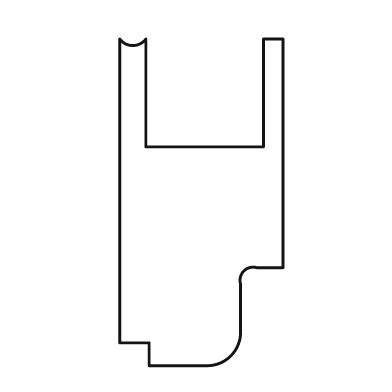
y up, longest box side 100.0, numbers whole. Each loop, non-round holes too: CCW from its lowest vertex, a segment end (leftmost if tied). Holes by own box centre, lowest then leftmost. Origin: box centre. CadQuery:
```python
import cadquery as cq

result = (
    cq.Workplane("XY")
    .moveTo(-16.0, -50.0)
    .lineTo(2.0, -50.0)
    .threePointArc((9.0, -47.0), (12.0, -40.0))
    .lineTo(12.0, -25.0)
    .threePointArc((13.0, -21.0), (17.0, -20.0))
    .lineTo(25.0, -20.0)
    .lineTo(25.0, 50.0)
    .lineTo(19.0, 50.0)
    .lineTo(19.0, 17.0)
    .lineTo(-17.0, 17.0)
    .lineTo(-17.0, 50.0)
    .threePointArc((-21.0, 48.0), (-25.0, 50.0))
    .lineTo(-25.0, -43.0)
    .lineTo(-16.0, -43.0)
    .close()
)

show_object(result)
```